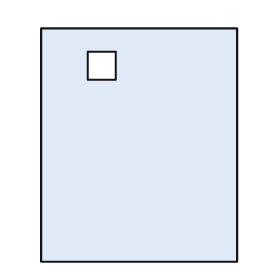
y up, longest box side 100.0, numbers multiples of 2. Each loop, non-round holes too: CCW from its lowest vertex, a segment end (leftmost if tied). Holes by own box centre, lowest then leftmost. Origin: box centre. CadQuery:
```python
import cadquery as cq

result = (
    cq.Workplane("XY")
    .moveTo(-42.0, -50.0)
    .lineTo(42.0, -50.0)
    .lineTo(42.0, 50.0)
    .lineTo(-42.0, 50.0)
    .close()
    .moveTo(-22.0, 28.0)
    .lineTo(-10.0, 28.0)
    .lineTo(-10.0, 40.0)
    .lineTo(-22.0, 40.0)
    .close()
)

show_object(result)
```